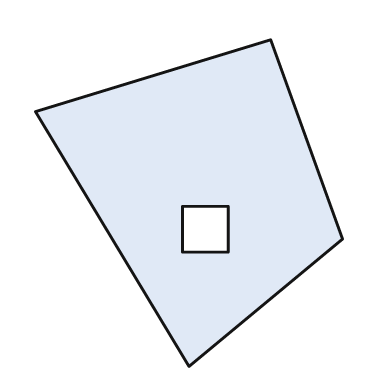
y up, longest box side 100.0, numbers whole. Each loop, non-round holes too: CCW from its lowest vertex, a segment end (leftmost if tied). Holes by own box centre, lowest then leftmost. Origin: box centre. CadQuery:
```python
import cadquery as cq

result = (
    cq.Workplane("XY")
    .moveTo(0.0, -50.0)
    .lineTo(47.0, -11.0)
    .lineTo(25.0, 50.0)
    .lineTo(-47.0, 28.0)
    .close()
    .moveTo(-2.0, -15.0)
    .lineTo(12.0, -15.0)
    .lineTo(12.0, -1.0)
    .lineTo(-2.0, -1.0)
    .close()
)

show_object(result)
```